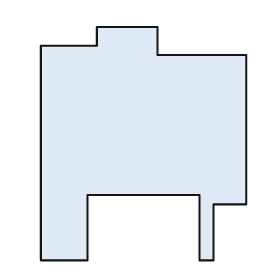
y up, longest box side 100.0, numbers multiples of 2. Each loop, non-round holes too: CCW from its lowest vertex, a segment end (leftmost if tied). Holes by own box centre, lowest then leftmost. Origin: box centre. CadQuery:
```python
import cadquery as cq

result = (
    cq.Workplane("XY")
    .moveTo(-44.0, -50.0)
    .lineTo(-24.0, -50.0)
    .lineTo(-24.0, -22.0)
    .lineTo(24.0, -22.0)
    .lineTo(24.0, -50.0)
    .lineTo(30.0, -50.0)
    .lineTo(30.0, -26.0)
    .lineTo(44.0, -26.0)
    .lineTo(44.0, 38.0)
    .lineTo(6.0, 38.0)
    .lineTo(6.0, 50.0)
    .lineTo(-20.0, 50.0)
    .lineTo(-20.0, 42.0)
    .lineTo(-44.0, 42.0)
    .close()
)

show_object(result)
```